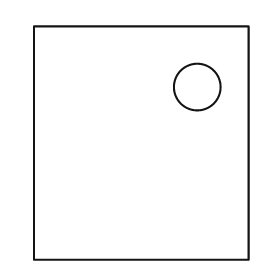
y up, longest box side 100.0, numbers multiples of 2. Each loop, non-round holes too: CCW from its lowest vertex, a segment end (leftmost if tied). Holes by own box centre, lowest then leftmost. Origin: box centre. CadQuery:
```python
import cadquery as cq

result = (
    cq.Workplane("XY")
    .moveTo(-46.0, -50.0)
    .lineTo(46.0, -50.0)
    .lineTo(46.0, 50.0)
    .lineTo(-46.0, 50.0)
    .close()
    .moveTo(24.0, 24.0)
    .circle(10.0)
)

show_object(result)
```